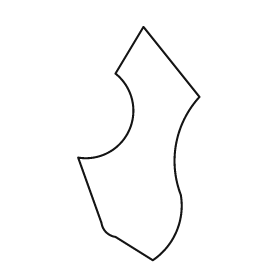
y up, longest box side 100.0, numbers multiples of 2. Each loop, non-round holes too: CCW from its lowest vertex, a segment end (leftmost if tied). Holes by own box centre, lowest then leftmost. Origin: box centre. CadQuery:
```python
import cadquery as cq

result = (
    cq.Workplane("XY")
    .moveTo(6.0, -50.0)
    .threePointArc((16.0, -38.0), (18.0, -22.0))
    .threePointArc((16.0, 0.0), (26.0, 20.0))
    .lineTo(2.0, 50.0)
    .lineTo(-10.0, 30.0)
    .threePointArc((-4.0, 6.0), (-26.0, -6.0))
    .lineTo(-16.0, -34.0)
    .threePointArc((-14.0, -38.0), (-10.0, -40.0))
    .close()
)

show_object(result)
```